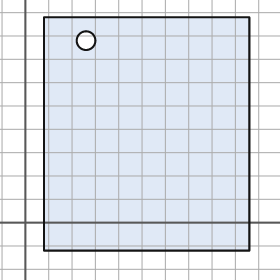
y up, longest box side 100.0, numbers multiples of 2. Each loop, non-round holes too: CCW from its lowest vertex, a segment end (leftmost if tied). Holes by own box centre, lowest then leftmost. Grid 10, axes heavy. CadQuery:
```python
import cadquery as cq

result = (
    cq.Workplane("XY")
    .moveTo(8.0, -12.0)
    .lineTo(96.0, -12.0)
    .lineTo(96.0, 88.0)
    .lineTo(8.0, 88.0)
    .close()
    .moveTo(26.0, 78.0)
    .circle(4.0)
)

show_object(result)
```